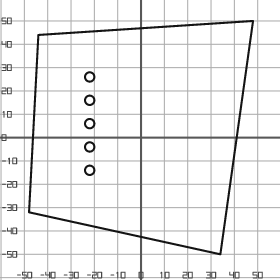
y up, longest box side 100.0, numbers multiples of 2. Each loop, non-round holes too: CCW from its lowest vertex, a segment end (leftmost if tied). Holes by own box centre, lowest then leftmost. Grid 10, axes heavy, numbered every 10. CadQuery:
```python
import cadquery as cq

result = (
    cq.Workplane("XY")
    .moveTo(34.0, -50.0)
    .lineTo(48.0, 50.0)
    .lineTo(-44.0, 44.0)
    .lineTo(-48.0, -32.0)
    .close()
    .moveTo(-22.0, -14.0)
    .circle(2.0)
    .moveTo(-22.0, -4.0)
    .circle(2.0)
    .moveTo(-22.0, 6.0)
    .circle(2.0)
    .moveTo(-22.0, 16.0)
    .circle(2.0)
    .moveTo(-22.0, 26.0)
    .circle(2.0)
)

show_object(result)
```